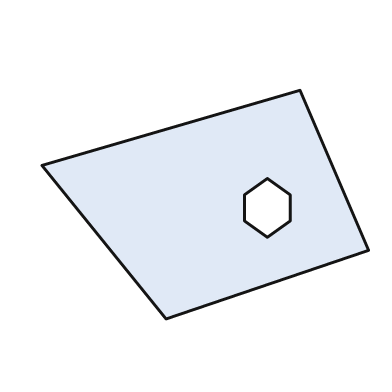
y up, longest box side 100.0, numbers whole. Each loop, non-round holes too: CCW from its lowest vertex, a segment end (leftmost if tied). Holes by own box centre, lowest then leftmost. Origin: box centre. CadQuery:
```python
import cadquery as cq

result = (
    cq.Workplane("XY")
    .moveTo(-12.0, -35.0)
    .lineTo(50.0, -14.0)
    .lineTo(29.0, 35.0)
    .lineTo(-50.0, 12.0)
    .close()
    .moveTo(19.0, -10.0)
    .lineTo(26.0, -5.0)
    .lineTo(26.0, 3.0)
    .lineTo(19.0, 8.0)
    .lineTo(12.0, 3.0)
    .lineTo(12.0, -5.0)
    .close()
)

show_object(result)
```